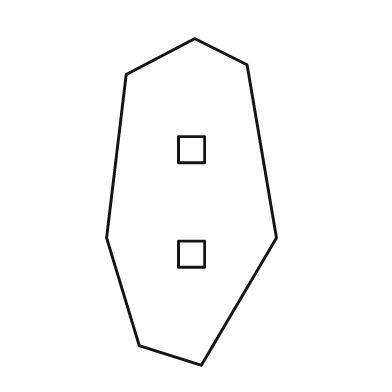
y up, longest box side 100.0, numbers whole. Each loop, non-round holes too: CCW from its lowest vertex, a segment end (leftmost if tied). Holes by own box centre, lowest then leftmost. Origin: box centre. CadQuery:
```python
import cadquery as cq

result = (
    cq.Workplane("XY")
    .moveTo(3.0, -50.0)
    .lineTo(26.0, -11.0)
    .lineTo(17.0, 42.0)
    .lineTo(1.0, 50.0)
    .lineTo(-20.0, 39.0)
    .lineTo(-26.0, -11.0)
    .lineTo(-16.0, -44.0)
    .close()
    .moveTo(-4.0, -20.0)
    .lineTo(4.0, -20.0)
    .lineTo(4.0, -12.0)
    .lineTo(-4.0, -12.0)
    .close()
    .moveTo(-4.0, 12.0)
    .lineTo(4.0, 12.0)
    .lineTo(4.0, 20.0)
    .lineTo(-4.0, 20.0)
    .close()
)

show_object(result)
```